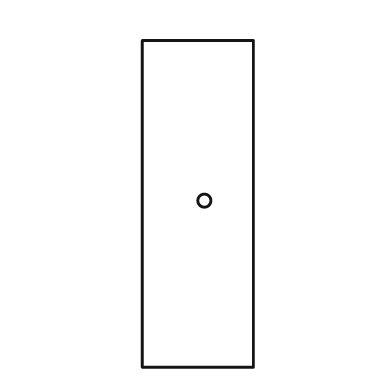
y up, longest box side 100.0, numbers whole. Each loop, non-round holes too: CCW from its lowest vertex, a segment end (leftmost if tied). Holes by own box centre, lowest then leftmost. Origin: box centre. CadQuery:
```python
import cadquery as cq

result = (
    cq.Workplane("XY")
    .moveTo(-17.0, -50.0)
    .lineTo(17.0, -50.0)
    .lineTo(17.0, 50.0)
    .lineTo(-17.0, 50.0)
    .close()
    .moveTo(2.0, 1.0)
    .circle(2.0)
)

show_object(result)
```